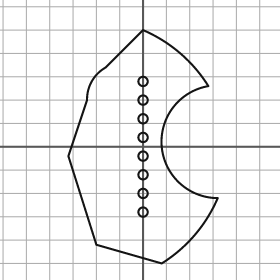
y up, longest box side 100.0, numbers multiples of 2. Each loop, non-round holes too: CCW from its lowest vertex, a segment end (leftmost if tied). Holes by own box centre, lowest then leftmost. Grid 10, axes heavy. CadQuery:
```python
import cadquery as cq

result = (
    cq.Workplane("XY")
    .moveTo(8.0, -50.0)
    .threePointArc((22.0, -38.0), (32.0, -22.0))
    .threePointArc((8.0, 0.0), (28.0, 26.0))
    .threePointArc((16.0, 40.0), (0.0, 50.0))
    .lineTo(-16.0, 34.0)
    .threePointArc((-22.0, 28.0), (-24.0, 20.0))
    .lineTo(-32.0, -4.0)
    .lineTo(-20.0, -42.0)
    .close()
    .moveTo(0.0, -28.0)
    .circle(2.0)
    .moveTo(0.0, -20.0)
    .circle(2.0)
    .moveTo(0.0, -12.0)
    .circle(2.0)
    .moveTo(0.0, -4.0)
    .circle(2.0)
    .moveTo(0.0, 4.0)
    .circle(2.0)
    .moveTo(0.0, 12.0)
    .circle(2.0)
    .moveTo(0.0, 20.0)
    .circle(2.0)
    .moveTo(0.0, 28.0)
    .circle(2.0)
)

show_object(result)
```